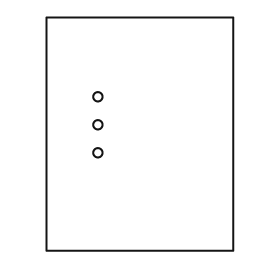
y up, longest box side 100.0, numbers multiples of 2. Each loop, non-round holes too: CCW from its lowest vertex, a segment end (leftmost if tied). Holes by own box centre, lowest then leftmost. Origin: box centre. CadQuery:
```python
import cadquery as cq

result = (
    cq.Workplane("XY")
    .moveTo(-40.0, -50.0)
    .lineTo(40.0, -50.0)
    .lineTo(40.0, 50.0)
    .lineTo(-40.0, 50.0)
    .close()
    .moveTo(-18.0, -8.0)
    .circle(2.0)
    .moveTo(-18.0, 4.0)
    .circle(2.0)
    .moveTo(-18.0, 16.0)
    .circle(2.0)
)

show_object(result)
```